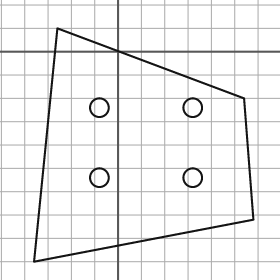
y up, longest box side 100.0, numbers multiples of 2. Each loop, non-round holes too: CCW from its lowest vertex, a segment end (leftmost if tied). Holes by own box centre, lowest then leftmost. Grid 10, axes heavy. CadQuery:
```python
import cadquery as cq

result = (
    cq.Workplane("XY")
    .moveTo(-36.0, -90.0)
    .lineTo(58.0, -72.0)
    .lineTo(54.0, -20.0)
    .lineTo(-26.0, 10.0)
    .close()
    .moveTo(-8.0, -54.0)
    .circle(4.0)
    .moveTo(32.0, -54.0)
    .circle(4.0)
    .moveTo(-8.0, -24.0)
    .circle(4.0)
    .moveTo(32.0, -24.0)
    .circle(4.0)
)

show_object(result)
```